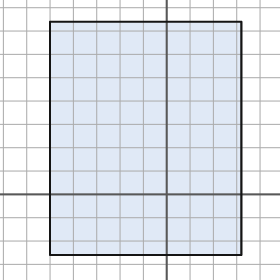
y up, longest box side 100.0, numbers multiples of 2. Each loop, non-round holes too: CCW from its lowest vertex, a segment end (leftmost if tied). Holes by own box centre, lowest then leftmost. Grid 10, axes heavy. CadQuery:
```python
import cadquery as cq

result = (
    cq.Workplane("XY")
    .moveTo(-50.0, -26.0)
    .lineTo(32.0, -26.0)
    .lineTo(32.0, 74.0)
    .lineTo(-50.0, 74.0)
    .close()
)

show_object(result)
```